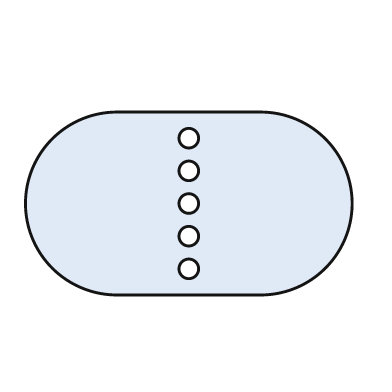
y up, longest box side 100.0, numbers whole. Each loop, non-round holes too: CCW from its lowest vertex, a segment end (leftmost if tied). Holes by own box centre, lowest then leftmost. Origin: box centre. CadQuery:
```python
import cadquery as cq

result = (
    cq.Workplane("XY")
    .moveTo(-22.0, -28.0)
    .lineTo(22.0, -28.0)
    .threePointArc((50.0, 0.0), (22.0, 28.0))
    .lineTo(-22.0, 28.0)
    .threePointArc((-50.0, 0.0), (-22.0, -28.0))
    .close()
    .moveTo(0.0, -20.0)
    .circle(3.0)
    .moveTo(0.0, -10.0)
    .circle(3.0)
    .moveTo(0.0, 0.0)
    .circle(3.0)
    .moveTo(0.0, 10.0)
    .circle(3.0)
    .moveTo(0.0, 20.0)
    .circle(3.0)
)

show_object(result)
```